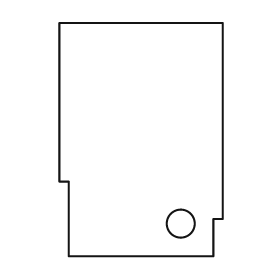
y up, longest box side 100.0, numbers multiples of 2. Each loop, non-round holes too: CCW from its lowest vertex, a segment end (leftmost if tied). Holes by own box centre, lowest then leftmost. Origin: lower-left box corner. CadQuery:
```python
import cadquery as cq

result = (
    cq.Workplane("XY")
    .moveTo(4.0, 0.0)
    .lineTo(66.0, 0.0)
    .lineTo(66.0, 16.0)
    .lineTo(70.0, 16.0)
    .lineTo(70.0, 100.0)
    .lineTo(0.0, 100.0)
    .lineTo(0.0, 32.0)
    .lineTo(4.0, 32.0)
    .close()
    .moveTo(52.0, 14.0)
    .circle(6.0)
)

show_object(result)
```